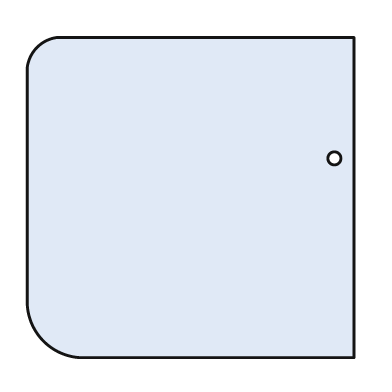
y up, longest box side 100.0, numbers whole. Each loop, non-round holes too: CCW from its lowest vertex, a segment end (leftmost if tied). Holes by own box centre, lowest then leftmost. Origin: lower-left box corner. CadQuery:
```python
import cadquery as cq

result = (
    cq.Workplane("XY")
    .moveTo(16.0, 0.0)
    .lineTo(100.0, 0.0)
    .lineTo(100.0, 98.0)
    .lineTo(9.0, 98.0)
    .threePointArc((3.0, 95.0), (0.0, 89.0))
    .lineTo(0.0, 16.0)
    .threePointArc((5.0, 5.0), (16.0, 0.0))
    .close()
    .moveTo(94.0, 61.0)
    .circle(2.0)
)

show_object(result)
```